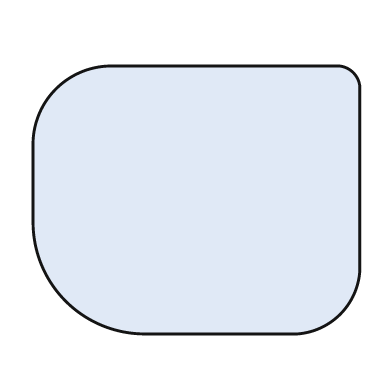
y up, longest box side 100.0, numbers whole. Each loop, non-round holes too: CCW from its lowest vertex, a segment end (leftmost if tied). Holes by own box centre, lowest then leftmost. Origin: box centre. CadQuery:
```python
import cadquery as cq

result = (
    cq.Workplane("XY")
    .moveTo(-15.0, -41.0)
    .lineTo(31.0, -41.0)
    .threePointArc((44.0, -35.0), (50.0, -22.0))
    .lineTo(50.0, 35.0)
    .threePointArc((48.0, 39.0), (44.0, 41.0))
    .lineTo(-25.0, 41.0)
    .threePointArc((-43.0, 34.0), (-50.0, 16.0))
    .lineTo(-50.0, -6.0)
    .threePointArc((-40.0, -31.0), (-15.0, -41.0))
    .close()
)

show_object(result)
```